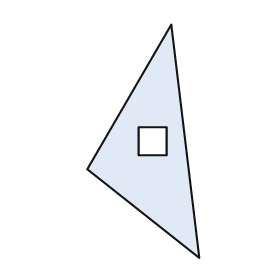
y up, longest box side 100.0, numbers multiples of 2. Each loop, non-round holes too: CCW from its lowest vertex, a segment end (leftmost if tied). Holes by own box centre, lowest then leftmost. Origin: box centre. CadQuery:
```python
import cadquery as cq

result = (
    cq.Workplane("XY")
    .moveTo(24.0, -50.0)
    .lineTo(12.0, 50.0)
    .lineTo(-24.0, -12.0)
    .close()
    .moveTo(-2.0, -6.0)
    .lineTo(10.0, -6.0)
    .lineTo(10.0, 6.0)
    .lineTo(-2.0, 6.0)
    .close()
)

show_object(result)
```